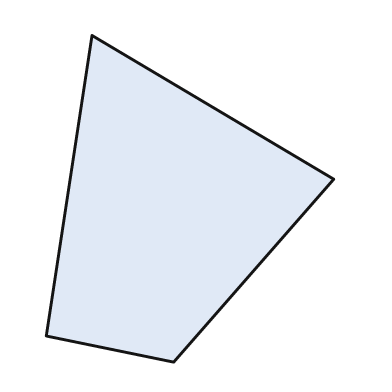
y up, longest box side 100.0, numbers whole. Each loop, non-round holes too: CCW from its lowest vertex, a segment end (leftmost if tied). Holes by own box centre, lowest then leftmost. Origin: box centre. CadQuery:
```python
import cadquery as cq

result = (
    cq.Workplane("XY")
    .moveTo(-5.0, -50.0)
    .lineTo(44.0, 6.0)
    .lineTo(-30.0, 50.0)
    .lineTo(-44.0, -42.0)
    .close()
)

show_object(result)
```